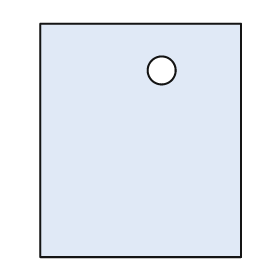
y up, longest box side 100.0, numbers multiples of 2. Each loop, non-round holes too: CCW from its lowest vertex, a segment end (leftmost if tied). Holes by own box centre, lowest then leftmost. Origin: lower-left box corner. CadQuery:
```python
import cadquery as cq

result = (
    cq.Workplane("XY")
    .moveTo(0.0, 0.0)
    .lineTo(86.0, 0.0)
    .lineTo(86.0, 100.0)
    .lineTo(0.0, 100.0)
    .close()
    .moveTo(52.0, 80.0)
    .circle(6.0)
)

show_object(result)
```